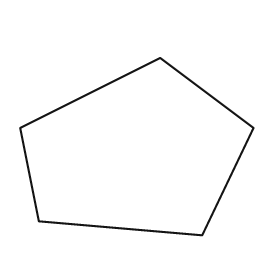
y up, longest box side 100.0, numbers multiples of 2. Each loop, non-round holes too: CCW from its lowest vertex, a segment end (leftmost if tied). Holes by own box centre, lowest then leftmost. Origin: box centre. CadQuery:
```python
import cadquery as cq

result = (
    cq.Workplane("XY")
    .moveTo(28.0, -38.0)
    .lineTo(50.0, 8.0)
    .lineTo(10.0, 38.0)
    .lineTo(-50.0, 8.0)
    .lineTo(-42.0, -32.0)
    .close()
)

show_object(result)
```